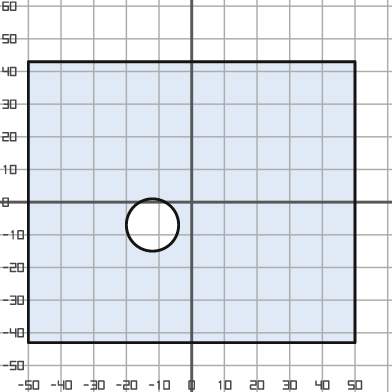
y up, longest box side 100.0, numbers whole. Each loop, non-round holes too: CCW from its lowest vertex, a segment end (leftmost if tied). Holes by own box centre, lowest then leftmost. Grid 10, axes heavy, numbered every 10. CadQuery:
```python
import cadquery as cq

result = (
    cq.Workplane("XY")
    .moveTo(-50.0, -43.0)
    .lineTo(50.0, -43.0)
    .lineTo(50.0, 43.0)
    .lineTo(-50.0, 43.0)
    .close()
    .moveTo(-12.0, -7.0)
    .circle(8.0)
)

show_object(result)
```